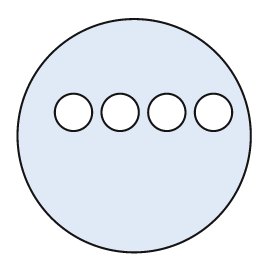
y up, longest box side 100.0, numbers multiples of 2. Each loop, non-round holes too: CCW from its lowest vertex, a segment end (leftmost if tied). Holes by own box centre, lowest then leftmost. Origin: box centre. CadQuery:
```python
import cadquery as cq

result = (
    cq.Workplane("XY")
    .moveTo(0.0, 0.0)
    .circle(50.0)
    .moveTo(-26.0, 10.0)
    .circle(8.0)
    .moveTo(-6.0, 10.0)
    .circle(8.0)
    .moveTo(14.0, 10.0)
    .circle(8.0)
    .moveTo(34.0, 10.0)
    .circle(8.0)
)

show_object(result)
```